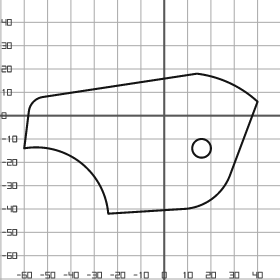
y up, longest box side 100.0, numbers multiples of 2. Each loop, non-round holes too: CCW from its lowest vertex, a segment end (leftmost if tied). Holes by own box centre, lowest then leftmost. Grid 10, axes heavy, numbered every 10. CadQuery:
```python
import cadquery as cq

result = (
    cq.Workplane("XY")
    .moveTo(-24.0, -42.0)
    .lineTo(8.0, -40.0)
    .threePointArc((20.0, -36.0), (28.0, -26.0))
    .lineTo(40.0, 6.0)
    .threePointArc((28.0, 14.0), (14.0, 18.0))
    .lineTo(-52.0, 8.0)
    .threePointArc((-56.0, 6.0), (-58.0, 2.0))
    .lineTo(-60.0, -14.0)
    .threePointArc((-36.0, -20.0), (-24.0, -42.0))
    .close()
    .moveTo(16.0, -14.0)
    .circle(4.0)
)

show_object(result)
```